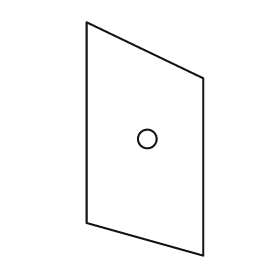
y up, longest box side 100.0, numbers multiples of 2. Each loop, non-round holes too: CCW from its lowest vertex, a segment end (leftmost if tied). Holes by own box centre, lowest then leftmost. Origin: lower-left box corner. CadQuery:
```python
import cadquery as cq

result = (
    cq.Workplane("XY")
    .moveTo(50.0, 0.0)
    .lineTo(50.0, 76.0)
    .lineTo(0.0, 100.0)
    .lineTo(0.0, 14.0)
    .close()
    .moveTo(26.0, 50.0)
    .circle(4.0)
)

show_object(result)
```